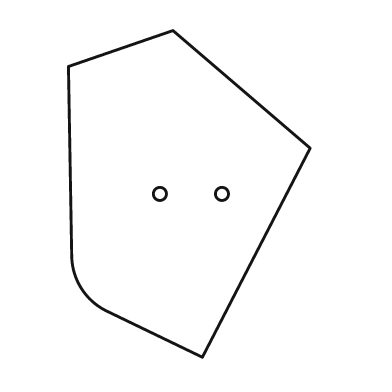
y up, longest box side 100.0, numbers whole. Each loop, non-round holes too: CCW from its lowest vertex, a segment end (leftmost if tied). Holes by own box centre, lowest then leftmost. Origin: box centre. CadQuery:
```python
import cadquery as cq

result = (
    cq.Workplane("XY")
    .moveTo(4.0, -50.0)
    .lineTo(37.0, 14.0)
    .lineTo(-5.0, 50.0)
    .lineTo(-37.0, 39.0)
    .lineTo(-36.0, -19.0)
    .threePointArc((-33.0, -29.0), (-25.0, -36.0))
    .close()
    .moveTo(-9.0, 0.0)
    .circle(2.0)
    .moveTo(10.0, 0.0)
    .circle(2.0)
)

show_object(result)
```